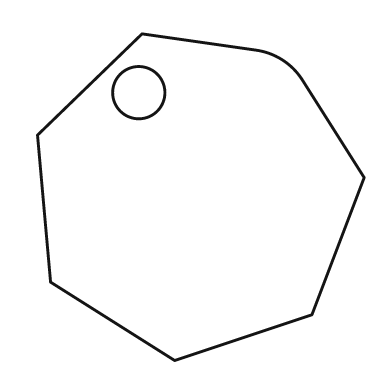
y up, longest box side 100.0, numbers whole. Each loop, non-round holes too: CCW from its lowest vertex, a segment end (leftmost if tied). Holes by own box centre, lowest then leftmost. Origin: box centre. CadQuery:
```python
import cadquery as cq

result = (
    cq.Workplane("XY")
    .moveTo(-8.0, -50.0)
    .lineTo(34.0, -36.0)
    .lineTo(50.0, 6.0)
    .lineTo(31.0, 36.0)
    .threePointArc((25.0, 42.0), (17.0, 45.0))
    .lineTo(-18.0, 50.0)
    .lineTo(-50.0, 19.0)
    .lineTo(-46.0, -26.0)
    .close()
    .moveTo(-19.0, 32.0)
    .circle(8.0)
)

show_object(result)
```